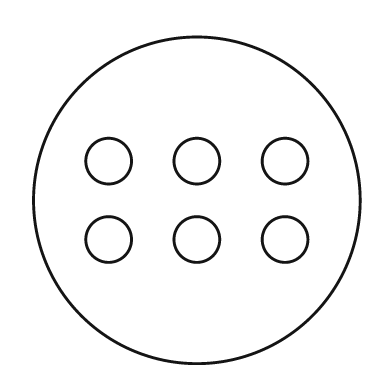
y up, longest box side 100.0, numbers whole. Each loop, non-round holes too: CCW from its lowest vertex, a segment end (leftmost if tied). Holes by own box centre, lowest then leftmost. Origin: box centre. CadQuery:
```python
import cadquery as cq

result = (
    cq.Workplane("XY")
    .moveTo(0.0, 0.0)
    .circle(50.0)
    .moveTo(-27.0, -12.0)
    .circle(7.0)
    .moveTo(0.0, -12.0)
    .circle(7.0)
    .moveTo(27.0, -12.0)
    .circle(7.0)
    .moveTo(-27.0, 12.0)
    .circle(7.0)
    .moveTo(0.0, 12.0)
    .circle(7.0)
    .moveTo(27.0, 12.0)
    .circle(7.0)
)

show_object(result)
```